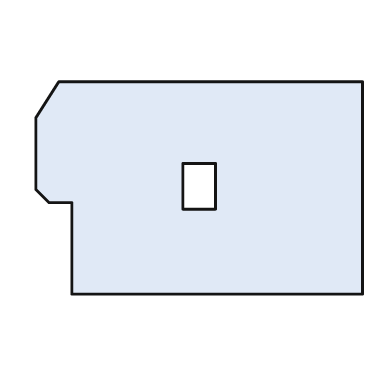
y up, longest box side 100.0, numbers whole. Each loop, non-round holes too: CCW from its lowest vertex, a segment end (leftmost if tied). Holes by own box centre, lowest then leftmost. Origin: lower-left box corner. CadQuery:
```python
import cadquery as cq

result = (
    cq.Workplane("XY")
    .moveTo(11.0, 0.0)
    .lineTo(100.0, 0.0)
    .lineTo(100.0, 65.0)
    .lineTo(7.0, 65.0)
    .lineTo(0.0, 54.0)
    .lineTo(0.0, 32.0)
    .lineTo(4.0, 28.0)
    .lineTo(11.0, 28.0)
    .close()
    .moveTo(45.0, 26.0)
    .lineTo(55.0, 26.0)
    .lineTo(55.0, 40.0)
    .lineTo(45.0, 40.0)
    .close()
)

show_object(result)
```